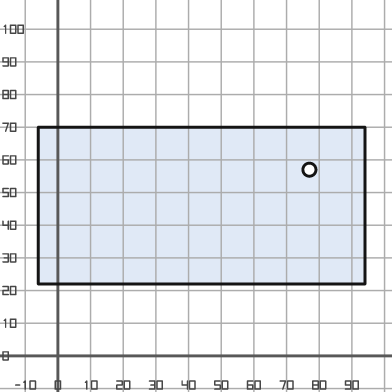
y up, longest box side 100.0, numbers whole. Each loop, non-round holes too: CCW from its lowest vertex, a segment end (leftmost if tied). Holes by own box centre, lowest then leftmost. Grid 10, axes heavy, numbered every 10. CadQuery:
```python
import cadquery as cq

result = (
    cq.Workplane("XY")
    .moveTo(-6.0, 22.0)
    .lineTo(94.0, 22.0)
    .lineTo(94.0, 70.0)
    .lineTo(-6.0, 70.0)
    .close()
    .moveTo(77.0, 57.0)
    .circle(2.0)
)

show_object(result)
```